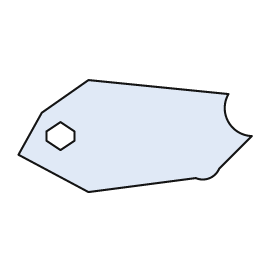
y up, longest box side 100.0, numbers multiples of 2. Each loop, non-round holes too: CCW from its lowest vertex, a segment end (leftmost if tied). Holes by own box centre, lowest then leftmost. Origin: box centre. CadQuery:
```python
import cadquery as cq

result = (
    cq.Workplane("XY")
    .moveTo(-20.0, -24.0)
    .lineTo(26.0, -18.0)
    .threePointArc((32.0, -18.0), (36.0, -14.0))
    .lineTo(50.0, 0.0)
    .threePointArc((40.0, 6.0), (40.0, 18.0))
    .lineTo(-20.0, 24.0)
    .lineTo(-40.0, 10.0)
    .lineTo(-50.0, -8.0)
    .close()
    .moveTo(-32.0, -6.0)
    .lineTo(-26.0, -2.0)
    .lineTo(-26.0, 2.0)
    .lineTo(-32.0, 6.0)
    .lineTo(-38.0, 2.0)
    .lineTo(-38.0, -2.0)
    .close()
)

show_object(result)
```